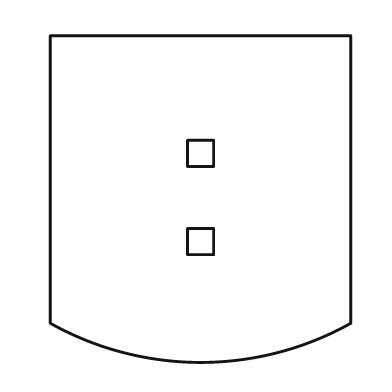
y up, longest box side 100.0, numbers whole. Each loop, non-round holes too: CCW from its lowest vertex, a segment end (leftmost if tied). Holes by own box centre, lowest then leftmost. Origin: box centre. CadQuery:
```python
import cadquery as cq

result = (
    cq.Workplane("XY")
    .moveTo(-46.0, -38.0)
    .threePointArc((0.0, -50.0), (46.0, -38.0))
    .lineTo(46.0, 50.0)
    .lineTo(-46.0, 50.0)
    .close()
    .moveTo(-4.0, -17.0)
    .lineTo(4.0, -17.0)
    .lineTo(4.0, -9.0)
    .lineTo(-4.0, -9.0)
    .close()
    .moveTo(-4.0, 10.0)
    .lineTo(4.0, 10.0)
    .lineTo(4.0, 18.0)
    .lineTo(-4.0, 18.0)
    .close()
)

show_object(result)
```